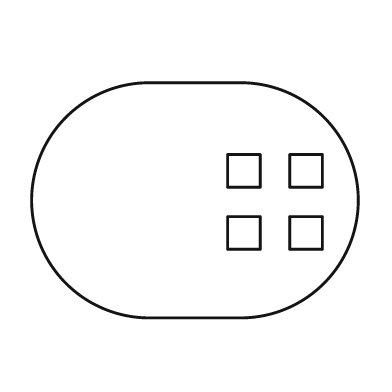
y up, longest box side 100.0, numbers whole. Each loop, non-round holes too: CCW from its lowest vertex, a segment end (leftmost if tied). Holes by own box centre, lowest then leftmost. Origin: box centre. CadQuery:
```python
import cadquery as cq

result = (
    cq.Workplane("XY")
    .moveTo(-14.0, -36.0)
    .lineTo(14.0, -36.0)
    .threePointArc((50.0, 0.0), (14.0, 36.0))
    .lineTo(-14.0, 36.0)
    .threePointArc((-50.0, 0.0), (-14.0, -36.0))
    .close()
    .moveTo(10.0, -15.0)
    .lineTo(20.0, -15.0)
    .lineTo(20.0, -5.0)
    .lineTo(10.0, -5.0)
    .close()
    .moveTo(29.0, -15.0)
    .lineTo(39.0, -15.0)
    .lineTo(39.0, -5.0)
    .lineTo(29.0, -5.0)
    .close()
    .moveTo(10.0, 4.0)
    .lineTo(20.0, 4.0)
    .lineTo(20.0, 14.0)
    .lineTo(10.0, 14.0)
    .close()
    .moveTo(29.0, 4.0)
    .lineTo(39.0, 4.0)
    .lineTo(39.0, 14.0)
    .lineTo(29.0, 14.0)
    .close()
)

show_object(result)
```